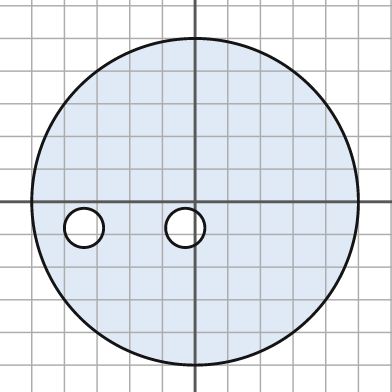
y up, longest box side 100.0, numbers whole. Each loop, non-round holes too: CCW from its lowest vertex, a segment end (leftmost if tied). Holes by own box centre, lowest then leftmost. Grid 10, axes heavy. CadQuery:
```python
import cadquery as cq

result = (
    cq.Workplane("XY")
    .moveTo(0.0, 0.0)
    .circle(50.0)
    .moveTo(-34.0, -8.0)
    .circle(6.0)
    .moveTo(-3.0, -8.0)
    .circle(6.0)
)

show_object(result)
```